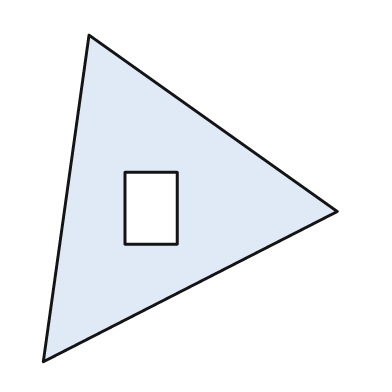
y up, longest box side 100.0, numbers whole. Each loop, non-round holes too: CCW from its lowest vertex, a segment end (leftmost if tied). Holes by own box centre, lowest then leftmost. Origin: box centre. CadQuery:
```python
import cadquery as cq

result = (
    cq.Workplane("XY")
    .moveTo(-45.0, -50.0)
    .lineTo(45.0, -4.0)
    .lineTo(-31.0, 50.0)
    .close()
    .moveTo(-20.0, -14.0)
    .lineTo(-4.0, -14.0)
    .lineTo(-4.0, 8.0)
    .lineTo(-20.0, 8.0)
    .close()
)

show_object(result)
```